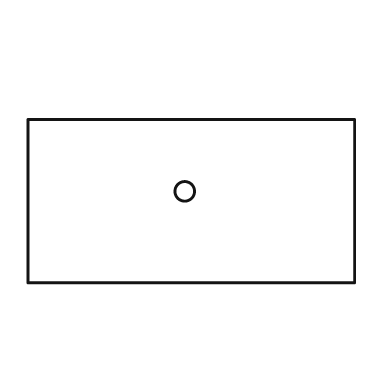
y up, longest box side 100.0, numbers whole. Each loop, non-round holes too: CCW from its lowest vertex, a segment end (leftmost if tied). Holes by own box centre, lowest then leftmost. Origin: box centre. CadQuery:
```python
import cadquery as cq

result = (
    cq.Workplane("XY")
    .moveTo(-50.0, -25.0)
    .lineTo(50.0, -25.0)
    .lineTo(50.0, 25.0)
    .lineTo(-50.0, 25.0)
    .close()
    .moveTo(-2.0, 3.0)
    .circle(3.0)
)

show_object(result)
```